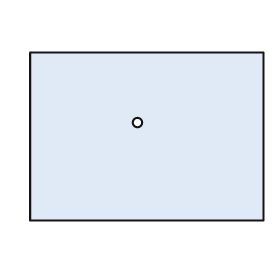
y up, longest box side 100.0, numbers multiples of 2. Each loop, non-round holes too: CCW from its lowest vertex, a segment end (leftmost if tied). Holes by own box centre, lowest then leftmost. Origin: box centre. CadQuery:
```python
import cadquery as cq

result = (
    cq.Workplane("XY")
    .moveTo(-50.0, -36.0)
    .lineTo(50.0, -36.0)
    .lineTo(50.0, 36.0)
    .lineTo(-50.0, 36.0)
    .close()
    .moveTo(-4.0, 6.0)
    .circle(2.0)
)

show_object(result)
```